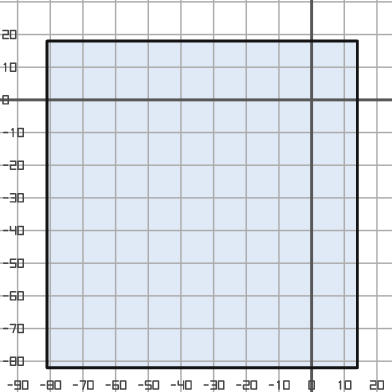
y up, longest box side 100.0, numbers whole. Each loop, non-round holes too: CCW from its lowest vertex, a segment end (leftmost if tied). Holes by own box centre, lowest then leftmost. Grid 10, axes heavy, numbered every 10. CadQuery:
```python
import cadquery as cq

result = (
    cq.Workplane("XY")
    .moveTo(-81.0, -82.0)
    .lineTo(14.0, -82.0)
    .lineTo(14.0, 18.0)
    .lineTo(-81.0, 18.0)
    .close()
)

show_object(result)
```